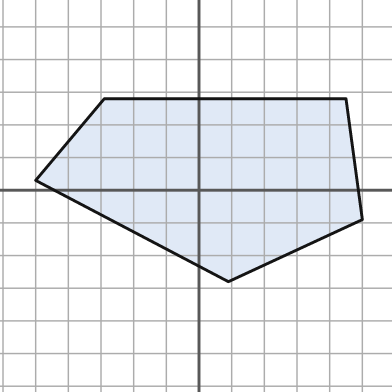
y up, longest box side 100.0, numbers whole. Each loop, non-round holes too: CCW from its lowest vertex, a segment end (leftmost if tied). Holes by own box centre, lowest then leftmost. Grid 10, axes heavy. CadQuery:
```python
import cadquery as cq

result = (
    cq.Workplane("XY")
    .moveTo(9.0, -28.0)
    .lineTo(50.0, -9.0)
    .lineTo(45.0, 28.0)
    .lineTo(-29.0, 28.0)
    .lineTo(-50.0, 3.0)
    .close()
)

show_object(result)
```